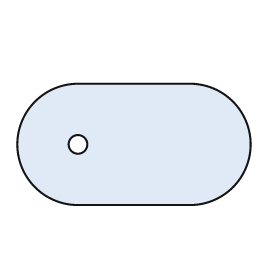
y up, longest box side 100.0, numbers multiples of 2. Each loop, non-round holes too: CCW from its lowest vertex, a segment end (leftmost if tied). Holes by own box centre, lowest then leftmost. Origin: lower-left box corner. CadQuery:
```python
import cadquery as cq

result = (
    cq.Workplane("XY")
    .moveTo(26.0, 0.0)
    .lineTo(74.0, 0.0)
    .threePointArc((100.0, 26.0), (74.0, 52.0))
    .lineTo(26.0, 52.0)
    .threePointArc((0.0, 26.0), (26.0, 0.0))
    .close()
    .moveTo(26.0, 26.0)
    .circle(4.0)
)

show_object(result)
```